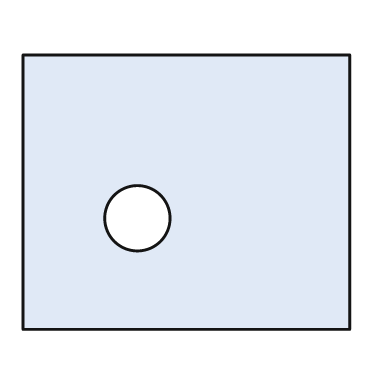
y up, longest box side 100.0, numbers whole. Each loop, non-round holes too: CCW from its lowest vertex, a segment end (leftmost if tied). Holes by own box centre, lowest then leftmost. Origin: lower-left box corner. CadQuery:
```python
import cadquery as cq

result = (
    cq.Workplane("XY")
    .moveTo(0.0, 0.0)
    .lineTo(100.0, 0.0)
    .lineTo(100.0, 84.0)
    .lineTo(0.0, 84.0)
    .close()
    .moveTo(35.0, 34.0)
    .circle(10.0)
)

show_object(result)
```